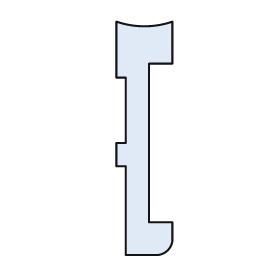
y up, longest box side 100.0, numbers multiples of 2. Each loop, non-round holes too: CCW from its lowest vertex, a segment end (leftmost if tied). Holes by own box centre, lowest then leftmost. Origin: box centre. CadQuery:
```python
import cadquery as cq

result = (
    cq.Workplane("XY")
    .moveTo(-8.0, -50.0)
    .lineTo(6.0, -50.0)
    .threePointArc((10.0, -48.0), (12.0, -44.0))
    .lineTo(12.0, -36.0)
    .lineTo(2.0, -36.0)
    .lineTo(2.0, 32.0)
    .lineTo(12.0, 32.0)
    .lineTo(12.0, 50.0)
    .threePointArc((0.0, 48.0), (-12.0, 50.0))
    .lineTo(-12.0, 26.0)
    .lineTo(-8.0, 26.0)
    .lineTo(-8.0, -2.0)
    .lineTo(-12.0, -2.0)
    .lineTo(-12.0, -12.0)
    .lineTo(-8.0, -12.0)
    .close()
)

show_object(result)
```